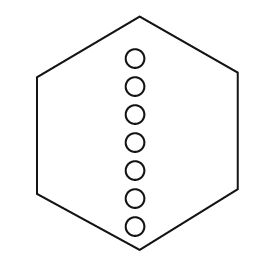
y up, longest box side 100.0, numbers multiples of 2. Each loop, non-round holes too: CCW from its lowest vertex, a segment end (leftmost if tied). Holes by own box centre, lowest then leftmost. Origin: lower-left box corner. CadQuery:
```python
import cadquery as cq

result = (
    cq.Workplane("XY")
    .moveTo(44.0, 0.0)
    .lineTo(86.0, 26.0)
    .lineTo(86.0, 76.0)
    .lineTo(44.0, 100.0)
    .lineTo(0.0, 74.0)
    .lineTo(0.0, 24.0)
    .close()
    .moveTo(42.0, 10.0)
    .circle(4.0)
    .moveTo(42.0, 22.0)
    .circle(4.0)
    .moveTo(42.0, 34.0)
    .circle(4.0)
    .moveTo(42.0, 46.0)
    .circle(4.0)
    .moveTo(42.0, 58.0)
    .circle(4.0)
    .moveTo(42.0, 70.0)
    .circle(4.0)
    .moveTo(42.0, 82.0)
    .circle(4.0)
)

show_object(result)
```